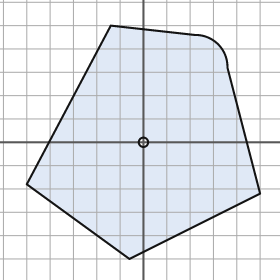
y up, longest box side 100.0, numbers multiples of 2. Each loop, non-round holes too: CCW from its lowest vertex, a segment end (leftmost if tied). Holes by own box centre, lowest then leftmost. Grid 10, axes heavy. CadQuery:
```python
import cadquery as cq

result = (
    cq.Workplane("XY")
    .moveTo(-6.0, -50.0)
    .lineTo(50.0, -22.0)
    .lineTo(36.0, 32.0)
    .threePointArc((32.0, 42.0), (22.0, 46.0))
    .lineTo(-14.0, 50.0)
    .lineTo(-50.0, -18.0)
    .close()
    .moveTo(0.0, 0.0)
    .circle(2.0)
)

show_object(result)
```